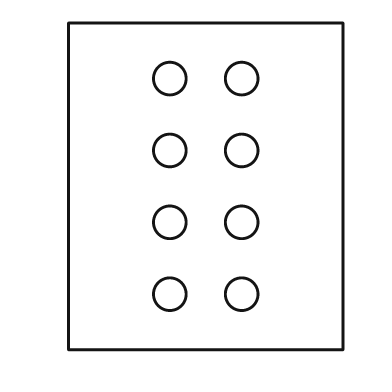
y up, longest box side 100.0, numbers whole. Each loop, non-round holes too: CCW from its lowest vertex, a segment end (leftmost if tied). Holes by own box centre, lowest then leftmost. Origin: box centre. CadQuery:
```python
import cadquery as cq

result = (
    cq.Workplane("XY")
    .moveTo(-42.0, -50.0)
    .lineTo(42.0, -50.0)
    .lineTo(42.0, 50.0)
    .lineTo(-42.0, 50.0)
    .close()
    .moveTo(-11.0, -33.0)
    .circle(5.0)
    .moveTo(11.0, -33.0)
    .circle(5.0)
    .moveTo(-11.0, -11.0)
    .circle(5.0)
    .moveTo(11.0, -11.0)
    .circle(5.0)
    .moveTo(-11.0, 11.0)
    .circle(5.0)
    .moveTo(11.0, 11.0)
    .circle(5.0)
    .moveTo(-11.0, 33.0)
    .circle(5.0)
    .moveTo(11.0, 33.0)
    .circle(5.0)
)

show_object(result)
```